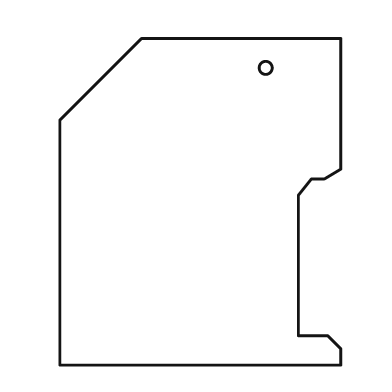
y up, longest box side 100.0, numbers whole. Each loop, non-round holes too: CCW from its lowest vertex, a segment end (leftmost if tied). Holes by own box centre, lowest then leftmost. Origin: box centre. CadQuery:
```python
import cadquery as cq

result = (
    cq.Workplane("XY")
    .moveTo(-43.0, -50.0)
    .lineTo(43.0, -50.0)
    .lineTo(43.0, -45.0)
    .lineTo(39.0, -41.0)
    .lineTo(30.0, -41.0)
    .lineTo(30.0, 2.0)
    .lineTo(34.0, 7.0)
    .lineTo(38.0, 7.0)
    .lineTo(43.0, 10.0)
    .lineTo(43.0, 50.0)
    .lineTo(-18.0, 50.0)
    .lineTo(-43.0, 25.0)
    .close()
    .moveTo(20.0, 41.0)
    .circle(2.0)
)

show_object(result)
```